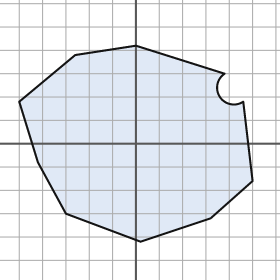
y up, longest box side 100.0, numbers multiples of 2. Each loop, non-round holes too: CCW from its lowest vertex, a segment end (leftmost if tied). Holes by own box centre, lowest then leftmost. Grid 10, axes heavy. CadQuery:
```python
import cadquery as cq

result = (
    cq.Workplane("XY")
    .moveTo(2.0, -42.0)
    .lineTo(32.0, -32.0)
    .lineTo(50.0, -16.0)
    .lineTo(46.0, 18.0)
    .threePointArc((36.0, 20.0), (38.0, 30.0))
    .lineTo(0.0, 42.0)
    .lineTo(-26.0, 38.0)
    .lineTo(-50.0, 18.0)
    .lineTo(-42.0, -8.0)
    .lineTo(-30.0, -30.0)
    .close()
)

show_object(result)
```